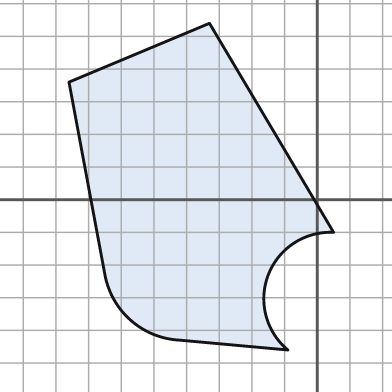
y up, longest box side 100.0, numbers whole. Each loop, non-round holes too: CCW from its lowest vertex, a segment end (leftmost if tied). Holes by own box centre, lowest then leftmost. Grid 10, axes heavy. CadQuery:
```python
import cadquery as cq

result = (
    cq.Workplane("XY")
    .moveTo(-9.0, -46.0)
    .threePointArc((-15.0, -23.0), (5.0, -10.0))
    .lineTo(-33.0, 54.0)
    .lineTo(-76.0, 36.0)
    .lineTo(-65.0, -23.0)
    .threePointArc((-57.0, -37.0), (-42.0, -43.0))
    .close()
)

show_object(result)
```